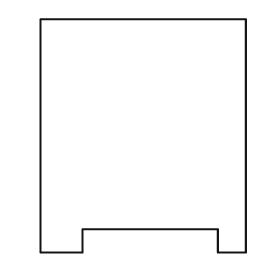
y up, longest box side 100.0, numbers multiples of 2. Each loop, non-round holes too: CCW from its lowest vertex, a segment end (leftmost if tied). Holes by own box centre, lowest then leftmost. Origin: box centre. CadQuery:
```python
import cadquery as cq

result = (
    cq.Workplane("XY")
    .moveTo(-44.0, -50.0)
    .lineTo(-26.0, -50.0)
    .lineTo(-26.0, -40.0)
    .lineTo(32.0, -40.0)
    .lineTo(32.0, -50.0)
    .lineTo(44.0, -50.0)
    .lineTo(44.0, 50.0)
    .lineTo(-44.0, 50.0)
    .close()
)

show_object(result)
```